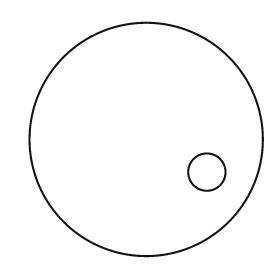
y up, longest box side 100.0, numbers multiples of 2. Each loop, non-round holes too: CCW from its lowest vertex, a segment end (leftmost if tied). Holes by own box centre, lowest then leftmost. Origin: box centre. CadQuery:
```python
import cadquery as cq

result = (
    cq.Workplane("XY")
    .moveTo(0.0, 0.0)
    .circle(50.0)
    .moveTo(26.0, -14.0)
    .circle(8.0)
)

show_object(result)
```